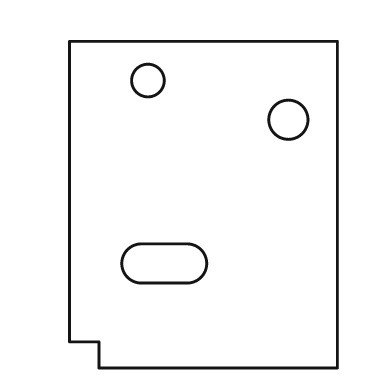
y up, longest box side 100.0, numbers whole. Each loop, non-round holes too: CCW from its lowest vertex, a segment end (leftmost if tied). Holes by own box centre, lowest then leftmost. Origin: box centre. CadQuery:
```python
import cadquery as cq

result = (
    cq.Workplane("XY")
    .moveTo(-32.0, -50.0)
    .lineTo(41.0, -50.0)
    .lineTo(41.0, 50.0)
    .lineTo(-41.0, 50.0)
    .lineTo(-41.0, -42.0)
    .lineTo(-32.0, -42.0)
    .close()
    .moveTo(-19.0, -24.0)
    .lineTo(-5.0, -24.0)
    .threePointArc((1.0, -18.0), (-5.0, -12.0))
    .lineTo(-19.0, -12.0)
    .threePointArc((-25.0, -18.0), (-19.0, -24.0))
    .close()
    .moveTo(26.0, 26.0)
    .circle(6.0)
    .moveTo(-17.0, 38.0)
    .circle(5.0)
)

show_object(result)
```